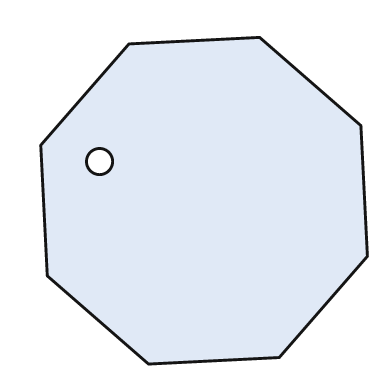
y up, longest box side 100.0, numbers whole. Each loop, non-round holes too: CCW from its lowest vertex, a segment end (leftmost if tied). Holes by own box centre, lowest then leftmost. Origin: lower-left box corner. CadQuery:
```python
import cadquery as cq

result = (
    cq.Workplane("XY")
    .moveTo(33.0, 0.0)
    .lineTo(73.0, 2.0)
    .lineTo(100.0, 33.0)
    .lineTo(98.0, 73.0)
    .lineTo(67.0, 100.0)
    .lineTo(27.0, 98.0)
    .lineTo(0.0, 67.0)
    .lineTo(2.0, 27.0)
    .close()
    .moveTo(18.0, 62.0)
    .circle(4.0)
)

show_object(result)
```